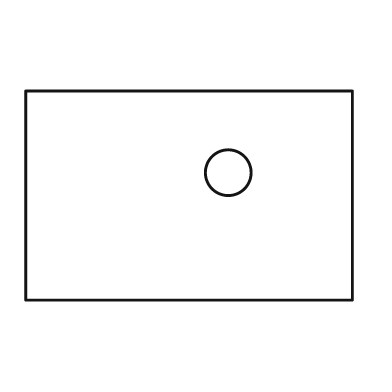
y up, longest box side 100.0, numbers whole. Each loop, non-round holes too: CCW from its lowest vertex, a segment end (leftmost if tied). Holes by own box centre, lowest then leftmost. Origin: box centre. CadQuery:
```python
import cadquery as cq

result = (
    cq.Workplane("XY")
    .moveTo(-50.0, -32.0)
    .lineTo(50.0, -32.0)
    .lineTo(50.0, 32.0)
    .lineTo(-50.0, 32.0)
    .close()
    .moveTo(12.0, 7.0)
    .circle(7.0)
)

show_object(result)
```